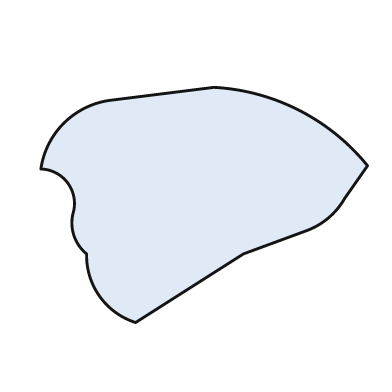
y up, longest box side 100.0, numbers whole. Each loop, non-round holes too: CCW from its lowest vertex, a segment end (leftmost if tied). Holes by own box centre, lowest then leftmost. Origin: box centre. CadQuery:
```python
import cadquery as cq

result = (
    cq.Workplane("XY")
    .moveTo(-21.0, -36.0)
    .lineTo(12.0, -15.0)
    .lineTo(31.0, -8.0)
    .threePointArc((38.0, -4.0), (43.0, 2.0))
    .lineTo(50.0, 12.0)
    .threePointArc((29.0, 29.0), (3.0, 36.0))
    .lineTo(-29.0, 32.0)
    .threePointArc((-43.0, 25.0), (-50.0, 11.0))
    .threePointArc((-42.0, 7.0), (-40.0, -2.0))
    .threePointArc((-40.0, -9.0), (-36.0, -15.0))
    .threePointArc((-32.0, -28.0), (-21.0, -36.0))
    .close()
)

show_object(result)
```